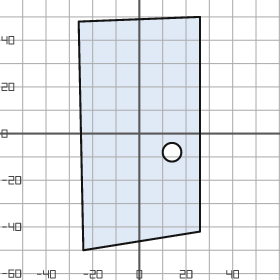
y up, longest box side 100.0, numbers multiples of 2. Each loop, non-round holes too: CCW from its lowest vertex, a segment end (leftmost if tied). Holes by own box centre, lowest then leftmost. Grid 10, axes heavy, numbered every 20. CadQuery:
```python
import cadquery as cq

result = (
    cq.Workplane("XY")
    .moveTo(-24.0, -50.0)
    .lineTo(26.0, -42.0)
    .lineTo(26.0, 50.0)
    .lineTo(-26.0, 48.0)
    .close()
    .moveTo(14.0, -8.0)
    .circle(4.0)
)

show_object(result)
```